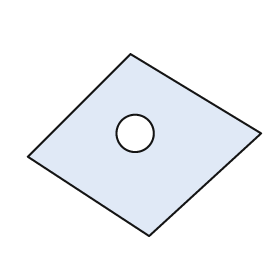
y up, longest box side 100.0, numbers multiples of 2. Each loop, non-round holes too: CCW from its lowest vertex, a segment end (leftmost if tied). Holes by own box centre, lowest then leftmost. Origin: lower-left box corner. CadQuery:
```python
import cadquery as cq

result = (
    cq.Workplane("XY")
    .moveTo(52.0, 0.0)
    .lineTo(100.0, 44.0)
    .lineTo(44.0, 78.0)
    .lineTo(0.0, 34.0)
    .close()
    .moveTo(46.0, 44.0)
    .circle(8.0)
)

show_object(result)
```